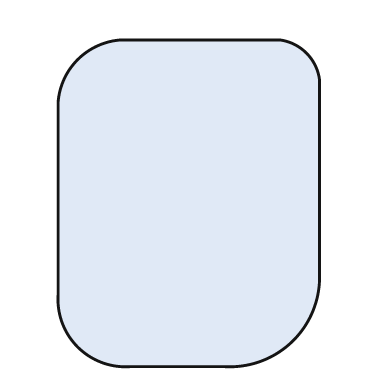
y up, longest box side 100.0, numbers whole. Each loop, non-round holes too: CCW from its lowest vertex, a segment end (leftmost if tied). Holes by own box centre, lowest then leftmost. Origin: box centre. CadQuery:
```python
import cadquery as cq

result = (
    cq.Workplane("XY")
    .moveTo(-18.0, -50.0)
    .lineTo(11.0, -50.0)
    .threePointArc((32.0, -42.0), (40.0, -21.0))
    .lineTo(40.0, 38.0)
    .threePointArc((36.0, 46.0), (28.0, 50.0))
    .lineTo(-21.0, 50.0)
    .threePointArc((-34.0, 44.0), (-40.0, 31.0))
    .lineTo(-40.0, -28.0)
    .threePointArc((-34.0, -44.0), (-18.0, -50.0))
    .close()
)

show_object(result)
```